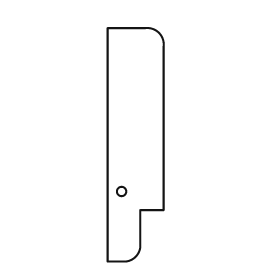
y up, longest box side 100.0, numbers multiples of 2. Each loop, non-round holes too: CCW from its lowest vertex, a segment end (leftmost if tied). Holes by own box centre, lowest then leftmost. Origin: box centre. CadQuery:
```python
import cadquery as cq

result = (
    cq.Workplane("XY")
    .moveTo(-12.0, -50.0)
    .lineTo(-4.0, -50.0)
    .threePointArc((0.0, -48.0), (2.0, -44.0))
    .lineTo(2.0, -28.0)
    .lineTo(12.0, -28.0)
    .lineTo(12.0, 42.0)
    .threePointArc((10.0, 48.0), (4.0, 50.0))
    .lineTo(-12.0, 50.0)
    .close()
    .moveTo(-6.0, -20.0)
    .circle(2.0)
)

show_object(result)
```